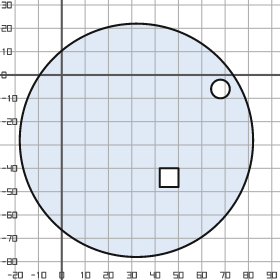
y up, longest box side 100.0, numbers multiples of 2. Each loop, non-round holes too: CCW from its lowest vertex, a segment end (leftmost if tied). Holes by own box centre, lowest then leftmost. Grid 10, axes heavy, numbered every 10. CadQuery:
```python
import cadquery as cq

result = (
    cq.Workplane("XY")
    .moveTo(32.0, -28.0)
    .circle(50.0)
    .moveTo(42.0, -48.0)
    .lineTo(50.0, -48.0)
    .lineTo(50.0, -40.0)
    .lineTo(42.0, -40.0)
    .close()
    .moveTo(68.0, -6.0)
    .circle(4.0)
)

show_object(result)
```